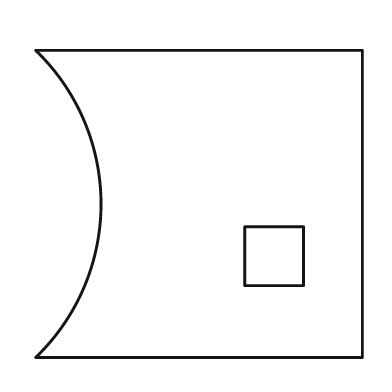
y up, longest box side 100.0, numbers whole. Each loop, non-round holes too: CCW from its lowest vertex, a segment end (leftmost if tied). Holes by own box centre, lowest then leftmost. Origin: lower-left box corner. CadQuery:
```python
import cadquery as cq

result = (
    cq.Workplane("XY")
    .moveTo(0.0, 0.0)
    .lineTo(100.0, 0.0)
    .lineTo(100.0, 94.0)
    .lineTo(0.0, 94.0)
    .threePointArc((20.0, 47.0), (0.0, 0.0))
    .close()
    .moveTo(64.0, 22.0)
    .lineTo(82.0, 22.0)
    .lineTo(82.0, 40.0)
    .lineTo(64.0, 40.0)
    .close()
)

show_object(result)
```